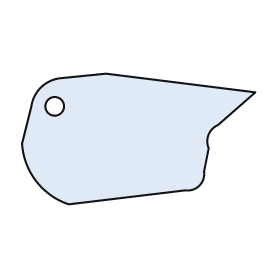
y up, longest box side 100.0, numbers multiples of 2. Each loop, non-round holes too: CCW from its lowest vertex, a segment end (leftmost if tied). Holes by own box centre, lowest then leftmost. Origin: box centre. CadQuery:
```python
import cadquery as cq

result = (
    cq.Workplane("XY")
    .moveTo(-30.0, -28.0)
    .lineTo(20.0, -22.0)
    .threePointArc((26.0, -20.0), (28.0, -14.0))
    .lineTo(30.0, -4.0)
    .threePointArc((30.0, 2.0), (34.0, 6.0))
    .lineTo(50.0, 20.0)
    .lineTo(-14.0, 28.0)
    .lineTo(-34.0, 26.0)
    .threePointArc((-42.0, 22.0), (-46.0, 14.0))
    .lineTo(-50.0, -2.0)
    .threePointArc((-44.0, -18.0), (-30.0, -28.0))
    .close()
    .moveTo(-36.0, 14.0)
    .circle(4.0)
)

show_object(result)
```